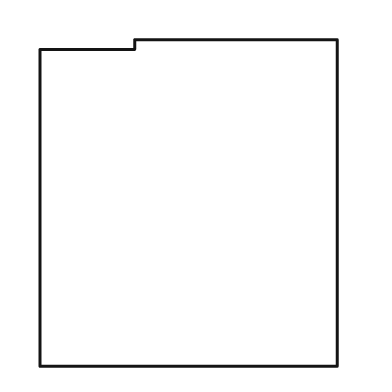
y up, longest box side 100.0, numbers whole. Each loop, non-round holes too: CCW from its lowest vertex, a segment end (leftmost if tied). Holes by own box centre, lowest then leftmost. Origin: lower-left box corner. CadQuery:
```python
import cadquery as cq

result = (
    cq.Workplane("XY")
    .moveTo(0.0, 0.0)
    .lineTo(91.0, 0.0)
    .lineTo(91.0, 100.0)
    .lineTo(29.0, 100.0)
    .lineTo(29.0, 97.0)
    .lineTo(0.0, 97.0)
    .close()
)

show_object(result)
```